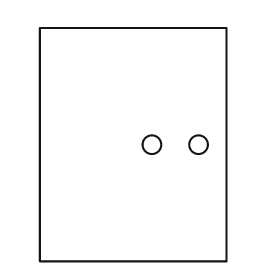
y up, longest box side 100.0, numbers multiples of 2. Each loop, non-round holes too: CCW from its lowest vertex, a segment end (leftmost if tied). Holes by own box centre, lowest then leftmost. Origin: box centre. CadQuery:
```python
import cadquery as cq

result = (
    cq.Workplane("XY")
    .moveTo(-40.0, -50.0)
    .lineTo(40.0, -50.0)
    .lineTo(40.0, 50.0)
    .lineTo(-40.0, 50.0)
    .close()
    .moveTo(8.0, 0.0)
    .circle(4.0)
    .moveTo(28.0, 0.0)
    .circle(4.0)
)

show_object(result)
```